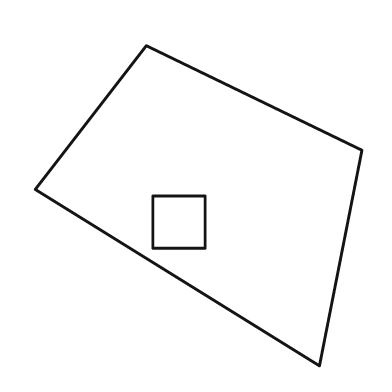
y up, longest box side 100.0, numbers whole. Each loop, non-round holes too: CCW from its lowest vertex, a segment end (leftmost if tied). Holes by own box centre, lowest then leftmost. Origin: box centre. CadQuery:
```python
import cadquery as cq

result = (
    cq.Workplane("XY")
    .moveTo(37.0, -49.0)
    .lineTo(50.0, 17.0)
    .lineTo(-16.0, 49.0)
    .lineTo(-50.0, 5.0)
    .close()
    .moveTo(-14.0, -13.0)
    .lineTo(2.0, -13.0)
    .lineTo(2.0, 3.0)
    .lineTo(-14.0, 3.0)
    .close()
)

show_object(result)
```